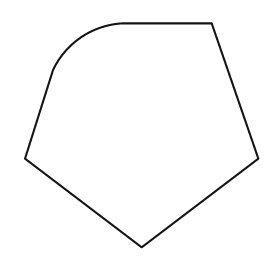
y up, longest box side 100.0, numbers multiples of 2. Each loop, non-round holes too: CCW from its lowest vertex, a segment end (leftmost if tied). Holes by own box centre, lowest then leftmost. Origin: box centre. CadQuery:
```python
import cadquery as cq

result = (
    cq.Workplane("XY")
    .moveTo(0.0, -48.0)
    .lineTo(50.0, -10.0)
    .lineTo(30.0, 48.0)
    .lineTo(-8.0, 48.0)
    .threePointArc((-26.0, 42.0), (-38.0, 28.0))
    .lineTo(-50.0, -10.0)
    .close()
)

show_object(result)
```